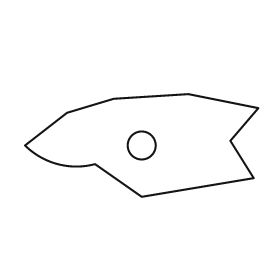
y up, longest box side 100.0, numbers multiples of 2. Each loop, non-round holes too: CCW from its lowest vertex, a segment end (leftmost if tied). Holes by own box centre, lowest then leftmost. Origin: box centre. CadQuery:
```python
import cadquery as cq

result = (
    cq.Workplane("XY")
    .moveTo(0.0, -22.0)
    .lineTo(48.0, -14.0)
    .lineTo(38.0, 2.0)
    .lineTo(50.0, 16.0)
    .lineTo(20.0, 22.0)
    .lineTo(-12.0, 20.0)
    .lineTo(-32.0, 14.0)
    .lineTo(-50.0, 0.0)
    .threePointArc((-36.0, -8.0), (-20.0, -8.0))
    .close()
    .moveTo(0.0, 0.0)
    .circle(6.0)
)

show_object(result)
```